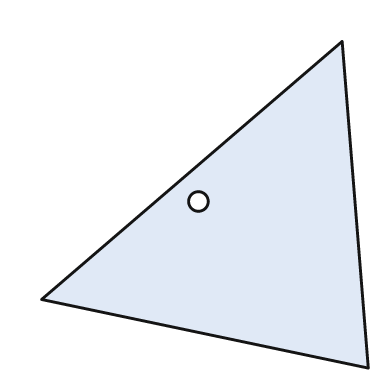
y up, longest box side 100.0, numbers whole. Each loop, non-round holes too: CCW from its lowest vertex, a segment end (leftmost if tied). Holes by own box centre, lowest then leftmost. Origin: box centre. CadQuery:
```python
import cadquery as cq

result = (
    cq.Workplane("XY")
    .moveTo(50.0, -50.0)
    .lineTo(42.0, 50.0)
    .lineTo(-50.0, -29.0)
    .close()
    .moveTo(-2.0, 1.0)
    .circle(3.0)
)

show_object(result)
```